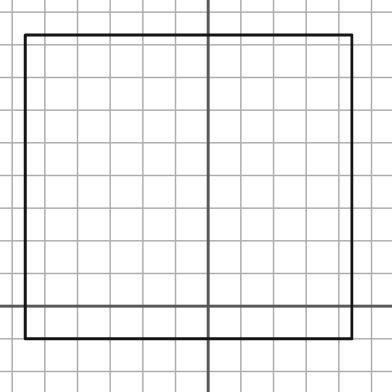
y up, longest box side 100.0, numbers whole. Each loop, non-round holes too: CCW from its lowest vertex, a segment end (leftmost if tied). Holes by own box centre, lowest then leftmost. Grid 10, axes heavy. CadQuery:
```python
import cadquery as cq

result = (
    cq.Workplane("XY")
    .moveTo(-56.0, -10.0)
    .lineTo(44.0, -10.0)
    .lineTo(44.0, 83.0)
    .lineTo(-56.0, 83.0)
    .close()
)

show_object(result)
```